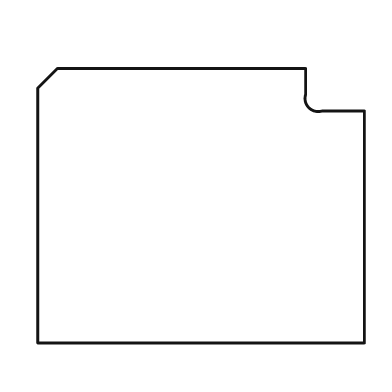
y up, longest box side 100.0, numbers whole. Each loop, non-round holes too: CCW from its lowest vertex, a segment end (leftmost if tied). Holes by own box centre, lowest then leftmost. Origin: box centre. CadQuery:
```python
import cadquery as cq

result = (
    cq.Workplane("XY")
    .moveTo(-50.0, -42.0)
    .lineTo(50.0, -42.0)
    .lineTo(50.0, 29.0)
    .lineTo(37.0, 29.0)
    .threePointArc((33.0, 30.0), (32.0, 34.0))
    .lineTo(32.0, 42.0)
    .lineTo(-44.0, 42.0)
    .lineTo(-50.0, 36.0)
    .close()
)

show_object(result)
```